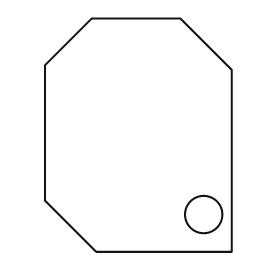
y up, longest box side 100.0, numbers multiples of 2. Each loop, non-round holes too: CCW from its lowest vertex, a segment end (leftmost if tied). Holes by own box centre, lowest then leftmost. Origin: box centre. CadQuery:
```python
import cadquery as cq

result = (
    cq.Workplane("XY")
    .moveTo(-18.0, -50.0)
    .lineTo(40.0, -50.0)
    .lineTo(40.0, 28.0)
    .lineTo(18.0, 50.0)
    .lineTo(-20.0, 50.0)
    .lineTo(-40.0, 30.0)
    .lineTo(-40.0, -28.0)
    .close()
    .moveTo(28.0, -34.0)
    .circle(8.0)
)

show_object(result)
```